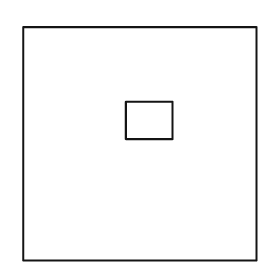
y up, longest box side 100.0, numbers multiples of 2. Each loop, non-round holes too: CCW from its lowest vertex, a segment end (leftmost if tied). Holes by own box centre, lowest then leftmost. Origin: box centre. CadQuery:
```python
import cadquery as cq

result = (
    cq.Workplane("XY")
    .moveTo(-50.0, -50.0)
    .lineTo(50.0, -50.0)
    .lineTo(50.0, 50.0)
    .lineTo(-50.0, 50.0)
    .close()
    .moveTo(-6.0, 2.0)
    .lineTo(14.0, 2.0)
    .lineTo(14.0, 18.0)
    .lineTo(-6.0, 18.0)
    .close()
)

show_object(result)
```